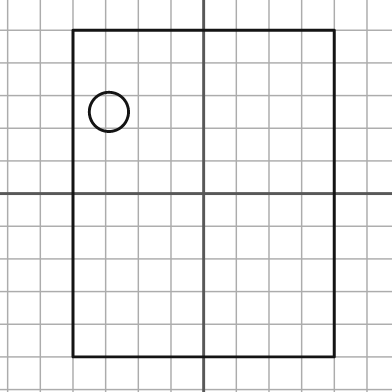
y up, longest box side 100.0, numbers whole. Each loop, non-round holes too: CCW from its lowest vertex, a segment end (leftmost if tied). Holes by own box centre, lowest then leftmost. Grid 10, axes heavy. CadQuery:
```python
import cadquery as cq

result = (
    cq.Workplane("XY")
    .moveTo(-40.0, -50.0)
    .lineTo(40.0, -50.0)
    .lineTo(40.0, 50.0)
    .lineTo(-40.0, 50.0)
    .close()
    .moveTo(-29.0, 25.0)
    .circle(6.0)
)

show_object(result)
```